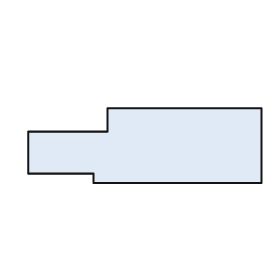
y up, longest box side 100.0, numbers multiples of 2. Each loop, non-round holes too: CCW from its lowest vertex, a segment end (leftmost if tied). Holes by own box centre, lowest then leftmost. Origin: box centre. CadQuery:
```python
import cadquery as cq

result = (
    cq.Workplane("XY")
    .moveTo(-22.0, -16.0)
    .lineTo(50.0, -16.0)
    .lineTo(50.0, 16.0)
    .lineTo(-16.0, 16.0)
    .lineTo(-16.0, 6.0)
    .lineTo(-50.0, 6.0)
    .lineTo(-50.0, -12.0)
    .lineTo(-22.0, -12.0)
    .close()
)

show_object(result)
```